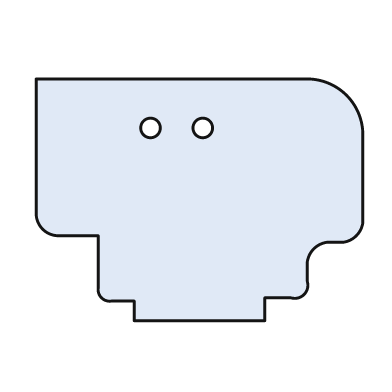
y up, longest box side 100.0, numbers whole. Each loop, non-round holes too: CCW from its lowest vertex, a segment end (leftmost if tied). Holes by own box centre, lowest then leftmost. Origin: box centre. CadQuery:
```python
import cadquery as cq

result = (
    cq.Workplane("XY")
    .moveTo(-20.0, -37.0)
    .lineTo(20.0, -37.0)
    .lineTo(20.0, -30.0)
    .lineTo(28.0, -30.0)
    .threePointArc((32.0, -29.0), (33.0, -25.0))
    .lineTo(33.0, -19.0)
    .threePointArc((35.0, -15.0), (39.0, -13.0))
    .lineTo(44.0, -13.0)
    .threePointArc((48.0, -11.0), (50.0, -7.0))
    .lineTo(50.0, 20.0)
    .threePointArc((45.0, 32.0), (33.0, 37.0))
    .lineTo(-50.0, 37.0)
    .lineTo(-50.0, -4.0)
    .threePointArc((-48.0, -9.0), (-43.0, -11.0))
    .lineTo(-31.0, -11.0)
    .lineTo(-31.0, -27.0)
    .threePointArc((-30.0, -30.0), (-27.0, -31.0))
    .lineTo(-20.0, -31.0)
    .close()
    .moveTo(-15.0, 22.0)
    .circle(3.0)
    .moveTo(1.0, 22.0)
    .circle(3.0)
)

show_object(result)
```